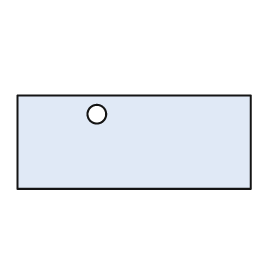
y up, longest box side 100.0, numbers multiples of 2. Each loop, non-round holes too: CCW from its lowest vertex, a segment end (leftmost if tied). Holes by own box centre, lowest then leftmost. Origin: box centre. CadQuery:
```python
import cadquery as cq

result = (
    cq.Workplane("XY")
    .moveTo(-50.0, -20.0)
    .lineTo(50.0, -20.0)
    .lineTo(50.0, 20.0)
    .lineTo(-50.0, 20.0)
    .close()
    .moveTo(-16.0, 12.0)
    .circle(4.0)
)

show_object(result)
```